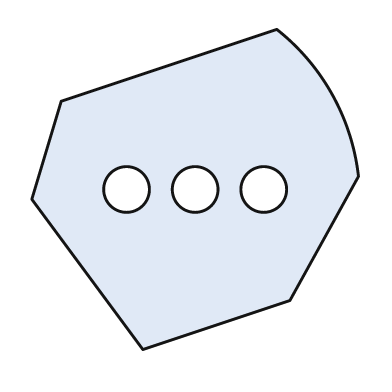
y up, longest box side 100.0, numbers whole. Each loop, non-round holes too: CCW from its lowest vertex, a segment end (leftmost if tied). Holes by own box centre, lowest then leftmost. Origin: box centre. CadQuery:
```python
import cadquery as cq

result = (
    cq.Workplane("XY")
    .moveTo(-16.0, -49.0)
    .lineTo(29.0, -34.0)
    .lineTo(50.0, 4.0)
    .threePointArc((42.0, 29.0), (25.0, 49.0))
    .lineTo(-41.0, 27.0)
    .lineTo(-50.0, -3.0)
    .close()
    .moveTo(-21.0, 0.0)
    .circle(7.0)
    .moveTo(0.0, 0.0)
    .circle(7.0)
    .moveTo(21.0, 0.0)
    .circle(7.0)
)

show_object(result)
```